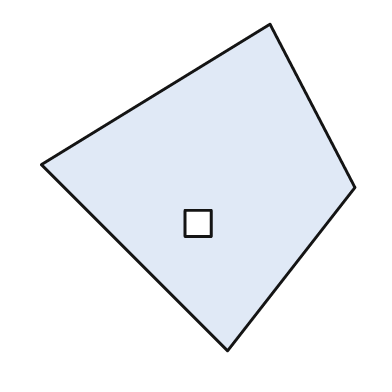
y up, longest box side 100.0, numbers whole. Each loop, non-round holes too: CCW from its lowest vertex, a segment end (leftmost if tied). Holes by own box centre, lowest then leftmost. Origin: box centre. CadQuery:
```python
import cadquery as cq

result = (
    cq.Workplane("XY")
    .moveTo(9.0, -50.0)
    .lineTo(48.0, 0.0)
    .lineTo(22.0, 50.0)
    .lineTo(-48.0, 7.0)
    .close()
    .moveTo(-4.0, -15.0)
    .lineTo(4.0, -15.0)
    .lineTo(4.0, -7.0)
    .lineTo(-4.0, -7.0)
    .close()
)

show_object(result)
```